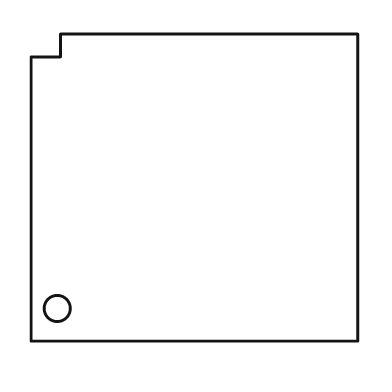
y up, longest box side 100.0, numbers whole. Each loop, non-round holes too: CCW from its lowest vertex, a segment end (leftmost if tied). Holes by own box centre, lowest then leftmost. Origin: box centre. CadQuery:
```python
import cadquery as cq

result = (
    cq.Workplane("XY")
    .moveTo(-50.0, -47.0)
    .lineTo(50.0, -47.0)
    .lineTo(50.0, 47.0)
    .lineTo(-41.0, 47.0)
    .lineTo(-41.0, 40.0)
    .lineTo(-50.0, 40.0)
    .close()
    .moveTo(-42.0, -37.0)
    .circle(4.0)
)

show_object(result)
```